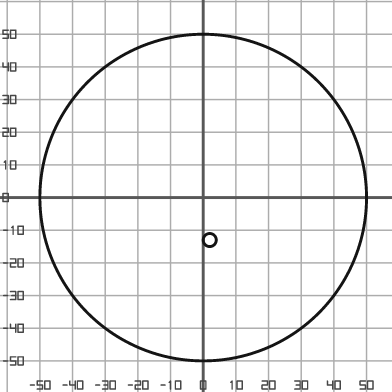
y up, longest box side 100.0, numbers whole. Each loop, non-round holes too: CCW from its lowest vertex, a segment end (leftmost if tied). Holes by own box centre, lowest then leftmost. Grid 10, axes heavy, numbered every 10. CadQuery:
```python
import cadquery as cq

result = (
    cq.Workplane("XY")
    .moveTo(0.0, 0.0)
    .circle(50.0)
    .moveTo(2.0, -13.0)
    .circle(2.0)
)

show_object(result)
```